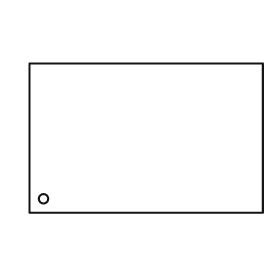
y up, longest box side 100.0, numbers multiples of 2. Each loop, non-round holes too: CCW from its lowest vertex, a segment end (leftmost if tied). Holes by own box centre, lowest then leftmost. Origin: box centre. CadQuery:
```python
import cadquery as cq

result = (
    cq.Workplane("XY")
    .moveTo(-50.0, -32.0)
    .lineTo(50.0, -32.0)
    .lineTo(50.0, 32.0)
    .lineTo(-50.0, 32.0)
    .close()
    .moveTo(-44.0, -26.0)
    .circle(2.0)
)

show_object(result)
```